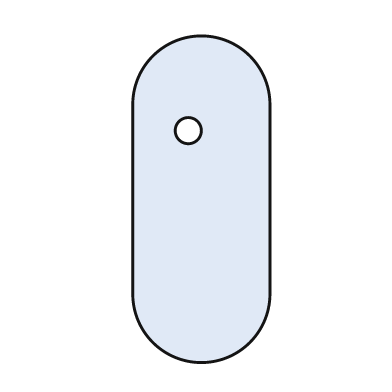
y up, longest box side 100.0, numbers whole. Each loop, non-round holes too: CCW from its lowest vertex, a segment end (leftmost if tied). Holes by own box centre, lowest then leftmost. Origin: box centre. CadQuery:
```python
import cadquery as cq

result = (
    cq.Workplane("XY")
    .moveTo(-21.0, -29.0)
    .threePointArc((0.0, -50.0), (21.0, -29.0))
    .lineTo(21.0, 29.0)
    .threePointArc((0.0, 50.0), (-21.0, 29.0))
    .close()
    .moveTo(-4.0, 21.0)
    .circle(4.0)
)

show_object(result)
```